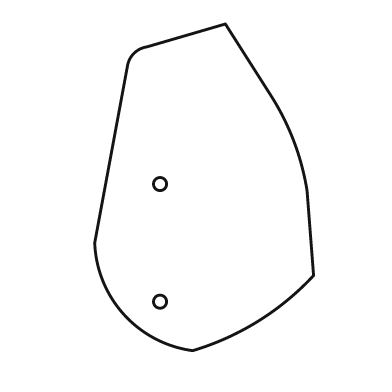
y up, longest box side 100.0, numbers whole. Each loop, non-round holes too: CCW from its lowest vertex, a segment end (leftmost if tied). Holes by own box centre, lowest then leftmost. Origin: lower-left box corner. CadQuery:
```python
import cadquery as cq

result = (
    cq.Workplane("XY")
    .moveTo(30.0, 0.0)
    .threePointArc((50.0, 9.0), (67.0, 23.0))
    .lineTo(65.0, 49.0)
    .threePointArc((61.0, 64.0), (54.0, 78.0))
    .lineTo(40.0, 100.0)
    .lineTo(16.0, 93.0)
    .threePointArc((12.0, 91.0), (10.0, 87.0))
    .lineTo(0.0, 33.0)
    .threePointArc((9.0, 11.0), (30.0, 0.0))
    .close()
    .moveTo(20.0, 15.0)
    .circle(2.0)
    .moveTo(20.0, 51.0)
    .circle(2.0)
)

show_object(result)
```